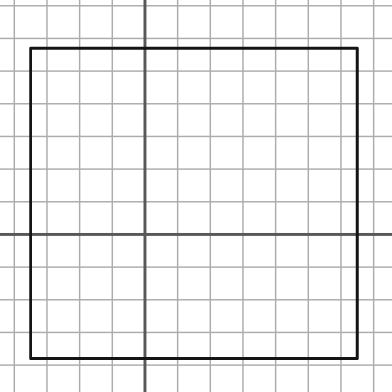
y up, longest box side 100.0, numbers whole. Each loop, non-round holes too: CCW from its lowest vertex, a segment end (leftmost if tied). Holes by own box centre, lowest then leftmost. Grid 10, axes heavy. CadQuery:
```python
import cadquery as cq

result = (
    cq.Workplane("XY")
    .moveTo(-35.0, -38.0)
    .lineTo(65.0, -38.0)
    .lineTo(65.0, 57.0)
    .lineTo(-35.0, 57.0)
    .close()
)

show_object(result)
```